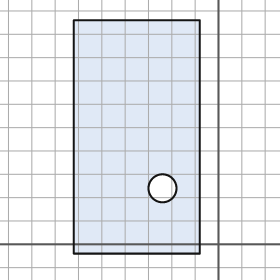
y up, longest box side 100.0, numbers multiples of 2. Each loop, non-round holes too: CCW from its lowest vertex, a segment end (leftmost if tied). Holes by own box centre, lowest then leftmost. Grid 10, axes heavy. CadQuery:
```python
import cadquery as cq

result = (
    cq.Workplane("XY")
    .moveTo(-62.0, -4.0)
    .lineTo(-8.0, -4.0)
    .lineTo(-8.0, 96.0)
    .lineTo(-62.0, 96.0)
    .close()
    .moveTo(-24.0, 24.0)
    .circle(6.0)
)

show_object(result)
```